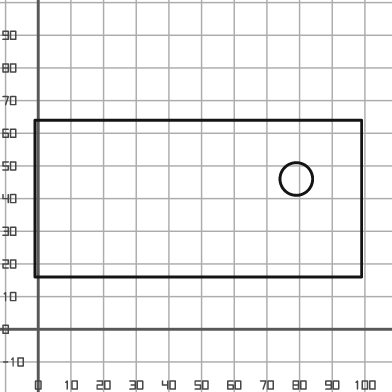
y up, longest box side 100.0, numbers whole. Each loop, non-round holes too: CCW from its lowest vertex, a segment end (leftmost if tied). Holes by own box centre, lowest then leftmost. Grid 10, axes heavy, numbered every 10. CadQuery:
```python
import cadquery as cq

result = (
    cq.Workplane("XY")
    .moveTo(-1.0, 16.0)
    .lineTo(99.0, 16.0)
    .lineTo(99.0, 64.0)
    .lineTo(-1.0, 64.0)
    .close()
    .moveTo(79.0, 46.0)
    .circle(5.0)
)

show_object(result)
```